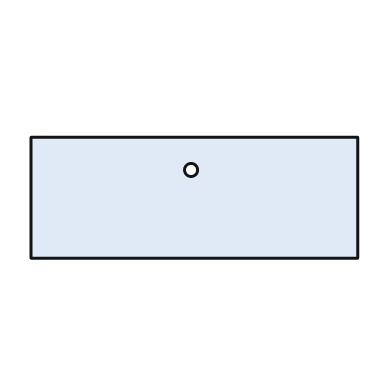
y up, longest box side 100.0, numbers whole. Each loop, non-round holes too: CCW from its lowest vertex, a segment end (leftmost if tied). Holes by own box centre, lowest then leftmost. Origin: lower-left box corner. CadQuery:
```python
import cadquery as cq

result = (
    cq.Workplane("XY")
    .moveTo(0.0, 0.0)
    .lineTo(100.0, 0.0)
    .lineTo(100.0, 37.0)
    .lineTo(0.0, 37.0)
    .close()
    .moveTo(49.0, 27.0)
    .circle(2.0)
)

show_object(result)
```